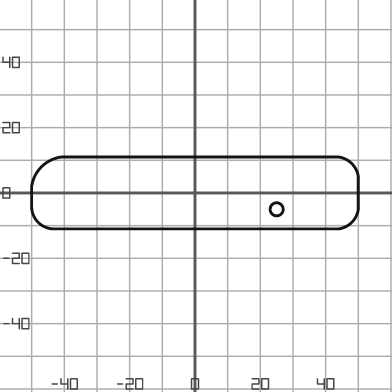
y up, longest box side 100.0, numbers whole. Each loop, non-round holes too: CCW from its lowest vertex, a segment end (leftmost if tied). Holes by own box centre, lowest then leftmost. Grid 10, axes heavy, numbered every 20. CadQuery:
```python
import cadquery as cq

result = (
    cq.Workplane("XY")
    .moveTo(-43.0, -11.0)
    .lineTo(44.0, -11.0)
    .threePointArc((48.0, -9.0), (50.0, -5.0))
    .lineTo(50.0, 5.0)
    .threePointArc((48.0, 9.0), (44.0, 11.0))
    .lineTo(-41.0, 11.0)
    .threePointArc((-47.0, 8.0), (-50.0, 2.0))
    .lineTo(-50.0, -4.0)
    .threePointArc((-48.0, -9.0), (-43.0, -11.0))
    .close()
    .moveTo(25.0, -5.0)
    .circle(2.0)
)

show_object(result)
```